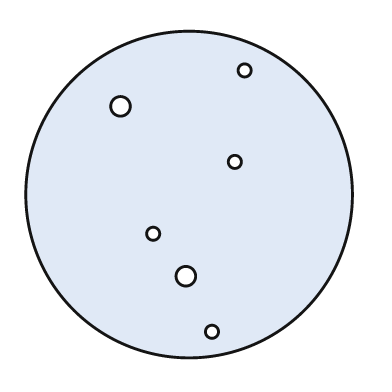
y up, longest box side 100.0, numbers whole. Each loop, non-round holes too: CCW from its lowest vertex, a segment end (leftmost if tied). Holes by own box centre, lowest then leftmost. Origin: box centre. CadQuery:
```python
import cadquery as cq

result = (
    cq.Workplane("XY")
    .moveTo(0.0, 0.0)
    .circle(50.0)
    .moveTo(7.0, -42.0)
    .circle(2.0)
    .moveTo(-1.0, -25.0)
    .circle(3.0)
    .moveTo(-11.0, -12.0)
    .circle(2.0)
    .moveTo(14.0, 10.0)
    .circle(2.0)
    .moveTo(-21.0, 27.0)
    .circle(3.0)
    .moveTo(17.0, 38.0)
    .circle(2.0)
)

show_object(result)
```